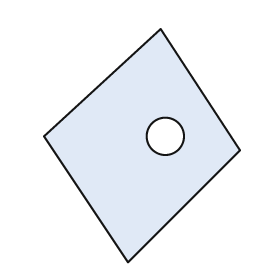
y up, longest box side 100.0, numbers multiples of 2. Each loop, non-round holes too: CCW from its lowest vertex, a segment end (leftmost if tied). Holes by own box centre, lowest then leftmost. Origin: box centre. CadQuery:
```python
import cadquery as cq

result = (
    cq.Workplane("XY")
    .moveTo(-6.0, -50.0)
    .lineTo(42.0, -2.0)
    .lineTo(8.0, 50.0)
    .lineTo(-42.0, 4.0)
    .close()
    .moveTo(10.0, 4.0)
    .circle(8.0)
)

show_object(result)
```